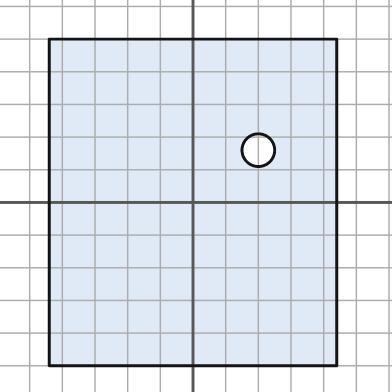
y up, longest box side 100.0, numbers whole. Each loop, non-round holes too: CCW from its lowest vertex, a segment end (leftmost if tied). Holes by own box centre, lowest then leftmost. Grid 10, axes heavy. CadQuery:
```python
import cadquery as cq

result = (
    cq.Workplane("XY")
    .moveTo(-44.0, -50.0)
    .lineTo(44.0, -50.0)
    .lineTo(44.0, 50.0)
    .lineTo(-44.0, 50.0)
    .close()
    .moveTo(20.0, 16.0)
    .circle(5.0)
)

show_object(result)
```